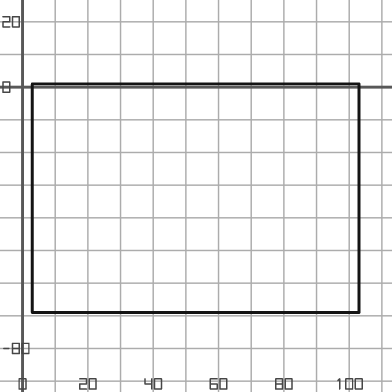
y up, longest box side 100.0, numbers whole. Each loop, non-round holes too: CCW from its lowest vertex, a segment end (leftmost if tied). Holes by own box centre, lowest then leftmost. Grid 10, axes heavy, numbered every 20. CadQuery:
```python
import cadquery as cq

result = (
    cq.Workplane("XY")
    .moveTo(3.0, -69.0)
    .lineTo(103.0, -69.0)
    .lineTo(103.0, 1.0)
    .lineTo(3.0, 1.0)
    .close()
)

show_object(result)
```